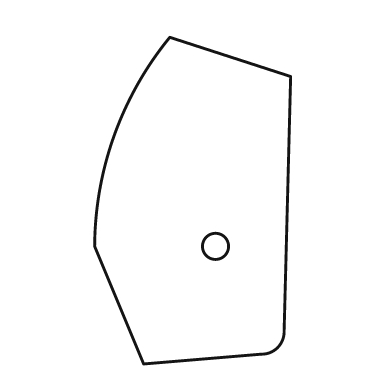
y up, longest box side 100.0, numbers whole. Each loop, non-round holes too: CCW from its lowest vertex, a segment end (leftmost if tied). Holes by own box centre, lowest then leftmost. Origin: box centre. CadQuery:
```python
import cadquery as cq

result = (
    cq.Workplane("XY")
    .moveTo(-15.0, -50.0)
    .lineTo(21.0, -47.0)
    .threePointArc((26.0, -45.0), (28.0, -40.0))
    .lineTo(30.0, 38.0)
    .lineTo(-7.0, 50.0)
    .threePointArc((-24.0, 20.0), (-30.0, -14.0))
    .close()
    .moveTo(7.0, -14.0)
    .circle(4.0)
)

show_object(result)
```